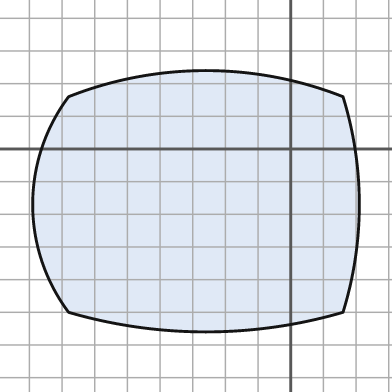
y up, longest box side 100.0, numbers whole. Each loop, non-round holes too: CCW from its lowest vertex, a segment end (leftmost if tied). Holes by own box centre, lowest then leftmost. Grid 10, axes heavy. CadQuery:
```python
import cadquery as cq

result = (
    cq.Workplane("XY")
    .moveTo(-68.0, -50.0)
    .threePointArc((-26.0, -56.0), (16.0, -50.0))
    .threePointArc((21.0, -17.0), (16.0, 16.0))
    .threePointArc((-26.0, 24.0), (-68.0, 16.0))
    .threePointArc((-79.0, -17.0), (-68.0, -50.0))
    .close()
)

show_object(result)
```